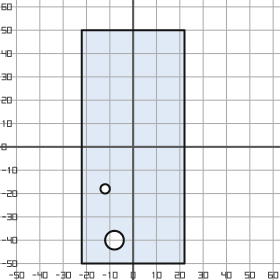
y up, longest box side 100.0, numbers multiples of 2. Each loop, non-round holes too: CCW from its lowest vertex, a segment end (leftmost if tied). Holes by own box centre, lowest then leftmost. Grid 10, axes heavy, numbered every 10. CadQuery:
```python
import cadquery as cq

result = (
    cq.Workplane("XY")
    .moveTo(-22.0, -50.0)
    .lineTo(22.0, -50.0)
    .lineTo(22.0, 50.0)
    .lineTo(-22.0, 50.0)
    .close()
    .moveTo(-8.0, -40.0)
    .circle(4.0)
    .moveTo(-12.0, -18.0)
    .circle(2.0)
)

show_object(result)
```